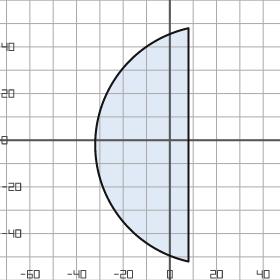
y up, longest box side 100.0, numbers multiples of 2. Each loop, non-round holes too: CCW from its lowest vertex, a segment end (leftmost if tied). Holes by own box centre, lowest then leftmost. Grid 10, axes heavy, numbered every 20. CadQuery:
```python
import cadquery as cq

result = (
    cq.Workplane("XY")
    .moveTo(8.0, -52.0)
    .lineTo(8.0, 48.0)
    .threePointArc((-32.0, -2.0), (8.0, -52.0))
    .close()
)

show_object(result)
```